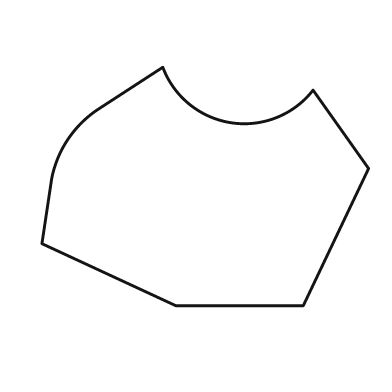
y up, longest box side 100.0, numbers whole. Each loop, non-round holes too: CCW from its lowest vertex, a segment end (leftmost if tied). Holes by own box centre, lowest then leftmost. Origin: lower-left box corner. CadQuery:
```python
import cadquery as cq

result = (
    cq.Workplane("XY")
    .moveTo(41.0, 0.0)
    .lineTo(80.0, 0.0)
    .lineTo(100.0, 42.0)
    .lineTo(83.0, 66.0)
    .threePointArc((58.0, 56.0), (37.0, 73.0))
    .lineTo(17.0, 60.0)
    .threePointArc((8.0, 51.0), (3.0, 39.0))
    .lineTo(0.0, 19.0)
    .close()
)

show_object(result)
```